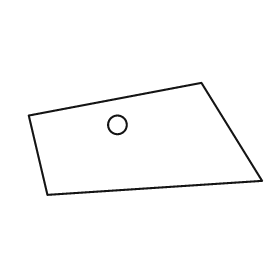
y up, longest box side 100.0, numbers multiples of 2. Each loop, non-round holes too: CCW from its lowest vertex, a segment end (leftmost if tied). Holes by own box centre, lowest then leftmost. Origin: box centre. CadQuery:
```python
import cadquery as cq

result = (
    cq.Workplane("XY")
    .moveTo(-42.0, -24.0)
    .lineTo(50.0, -18.0)
    .lineTo(24.0, 24.0)
    .lineTo(-50.0, 10.0)
    .close()
    .moveTo(-12.0, 6.0)
    .circle(4.0)
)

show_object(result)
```